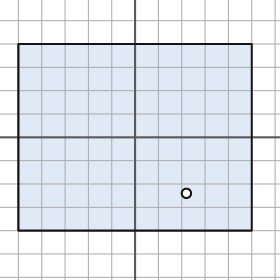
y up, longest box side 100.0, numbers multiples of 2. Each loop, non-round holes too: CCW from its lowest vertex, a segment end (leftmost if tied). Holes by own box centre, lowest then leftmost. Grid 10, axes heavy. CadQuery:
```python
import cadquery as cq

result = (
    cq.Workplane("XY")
    .moveTo(-50.0, -40.0)
    .lineTo(50.0, -40.0)
    .lineTo(50.0, 40.0)
    .lineTo(-50.0, 40.0)
    .close()
    .moveTo(22.0, -24.0)
    .circle(2.0)
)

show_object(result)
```